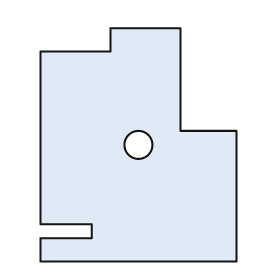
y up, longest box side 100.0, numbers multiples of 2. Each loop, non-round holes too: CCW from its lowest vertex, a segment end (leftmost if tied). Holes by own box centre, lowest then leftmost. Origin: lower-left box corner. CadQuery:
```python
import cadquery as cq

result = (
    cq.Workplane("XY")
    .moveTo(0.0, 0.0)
    .lineTo(84.0, 0.0)
    .lineTo(84.0, 56.0)
    .lineTo(60.0, 56.0)
    .lineTo(60.0, 100.0)
    .lineTo(30.0, 100.0)
    .lineTo(30.0, 90.0)
    .lineTo(0.0, 90.0)
    .lineTo(0.0, 16.0)
    .lineTo(22.0, 16.0)
    .lineTo(22.0, 10.0)
    .lineTo(0.0, 10.0)
    .close()
    .moveTo(42.0, 50.0)
    .circle(6.0)
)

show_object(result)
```